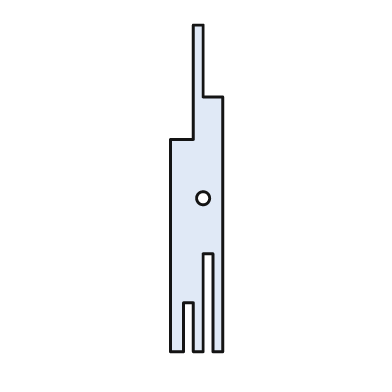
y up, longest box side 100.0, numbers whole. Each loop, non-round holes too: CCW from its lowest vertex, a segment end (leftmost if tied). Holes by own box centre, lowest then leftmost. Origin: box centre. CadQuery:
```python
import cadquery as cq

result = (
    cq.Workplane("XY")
    .moveTo(-8.0, -50.0)
    .lineTo(-4.0, -50.0)
    .lineTo(-4.0, -35.0)
    .lineTo(-1.0, -35.0)
    .lineTo(-1.0, -50.0)
    .lineTo(2.0, -50.0)
    .lineTo(2.0, -20.0)
    .lineTo(5.0, -20.0)
    .lineTo(5.0, -50.0)
    .lineTo(8.0, -50.0)
    .lineTo(8.0, 28.0)
    .lineTo(2.0, 28.0)
    .lineTo(2.0, 50.0)
    .lineTo(-1.0, 50.0)
    .lineTo(-1.0, 15.0)
    .lineTo(-8.0, 15.0)
    .close()
    .moveTo(2.0, -3.0)
    .circle(2.0)
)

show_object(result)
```